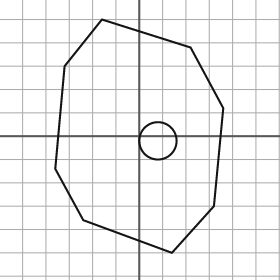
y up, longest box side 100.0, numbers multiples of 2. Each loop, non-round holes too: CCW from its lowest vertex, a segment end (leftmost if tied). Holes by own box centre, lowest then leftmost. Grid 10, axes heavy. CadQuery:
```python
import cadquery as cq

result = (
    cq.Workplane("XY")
    .moveTo(14.0, -50.0)
    .lineTo(32.0, -30.0)
    .lineTo(36.0, 12.0)
    .lineTo(22.0, 38.0)
    .lineTo(-16.0, 50.0)
    .lineTo(-32.0, 30.0)
    .lineTo(-36.0, -14.0)
    .lineTo(-24.0, -36.0)
    .close()
    .moveTo(8.0, -2.0)
    .circle(8.0)
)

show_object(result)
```